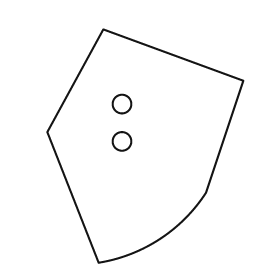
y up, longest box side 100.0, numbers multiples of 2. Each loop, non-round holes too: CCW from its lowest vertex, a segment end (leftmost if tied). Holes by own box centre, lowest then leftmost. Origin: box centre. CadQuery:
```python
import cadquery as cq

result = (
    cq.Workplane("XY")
    .moveTo(-20.0, -50.0)
    .threePointArc((6.0, -40.0), (26.0, -20.0))
    .lineTo(42.0, 28.0)
    .lineTo(-18.0, 50.0)
    .lineTo(-42.0, 6.0)
    .close()
    .moveTo(-10.0, 2.0)
    .circle(4.0)
    .moveTo(-10.0, 18.0)
    .circle(4.0)
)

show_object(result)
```